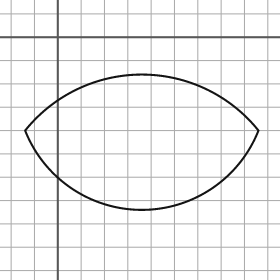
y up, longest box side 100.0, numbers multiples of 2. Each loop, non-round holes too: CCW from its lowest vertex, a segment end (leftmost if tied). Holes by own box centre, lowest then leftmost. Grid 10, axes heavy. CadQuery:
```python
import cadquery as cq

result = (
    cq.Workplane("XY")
    .moveTo(-14.0, -40.0)
    .threePointArc((36.0, -74.0), (86.0, -40.0))
    .threePointArc((36.0, -16.0), (-14.0, -40.0))
    .close()
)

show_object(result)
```